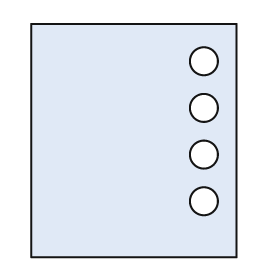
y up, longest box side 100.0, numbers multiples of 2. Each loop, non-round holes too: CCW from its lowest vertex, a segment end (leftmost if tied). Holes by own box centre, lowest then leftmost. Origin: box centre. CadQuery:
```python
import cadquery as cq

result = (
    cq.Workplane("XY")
    .moveTo(-44.0, -50.0)
    .lineTo(44.0, -50.0)
    .lineTo(44.0, 50.0)
    .lineTo(-44.0, 50.0)
    .close()
    .moveTo(30.0, -26.0)
    .circle(6.0)
    .moveTo(30.0, -6.0)
    .circle(6.0)
    .moveTo(30.0, 14.0)
    .circle(6.0)
    .moveTo(30.0, 34.0)
    .circle(6.0)
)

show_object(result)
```